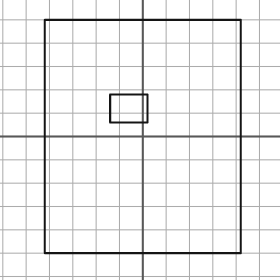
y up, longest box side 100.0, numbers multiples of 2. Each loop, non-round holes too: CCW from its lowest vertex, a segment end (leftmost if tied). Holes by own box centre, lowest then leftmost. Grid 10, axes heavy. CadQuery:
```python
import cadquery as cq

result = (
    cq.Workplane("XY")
    .moveTo(-42.0, -50.0)
    .lineTo(42.0, -50.0)
    .lineTo(42.0, 50.0)
    .lineTo(-42.0, 50.0)
    .close()
    .moveTo(-14.0, 6.0)
    .lineTo(2.0, 6.0)
    .lineTo(2.0, 18.0)
    .lineTo(-14.0, 18.0)
    .close()
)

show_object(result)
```